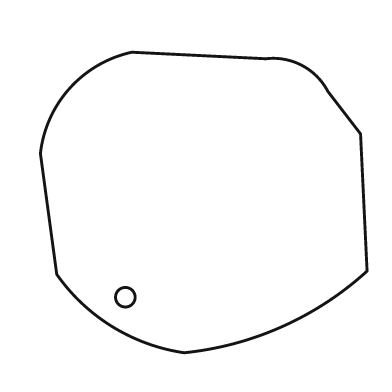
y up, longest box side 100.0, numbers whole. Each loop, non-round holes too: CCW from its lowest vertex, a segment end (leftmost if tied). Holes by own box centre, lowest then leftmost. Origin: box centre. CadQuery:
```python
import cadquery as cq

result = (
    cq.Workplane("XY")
    .moveTo(-6.0, -46.0)
    .threePointArc((24.0, -38.0), (50.0, -21.0))
    .lineTo(48.0, 21.0)
    .lineTo(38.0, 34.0)
    .threePointArc((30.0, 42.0), (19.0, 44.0))
    .lineTo(-22.0, 46.0)
    .threePointArc((-41.0, 35.0), (-50.0, 15.0))
    .lineTo(-45.0, -22.0)
    .threePointArc((-28.0, -38.0), (-6.0, -46.0))
    .close()
    .moveTo(-24.0, -29.0)
    .circle(3.0)
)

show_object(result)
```